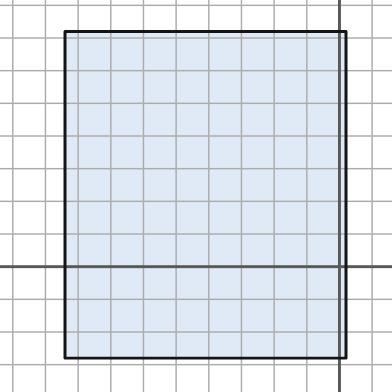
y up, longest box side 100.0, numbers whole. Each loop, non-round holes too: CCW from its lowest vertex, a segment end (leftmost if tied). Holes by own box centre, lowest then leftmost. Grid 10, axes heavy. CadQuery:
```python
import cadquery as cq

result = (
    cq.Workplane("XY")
    .moveTo(-84.0, -28.0)
    .lineTo(2.0, -28.0)
    .lineTo(2.0, 72.0)
    .lineTo(-84.0, 72.0)
    .close()
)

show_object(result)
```